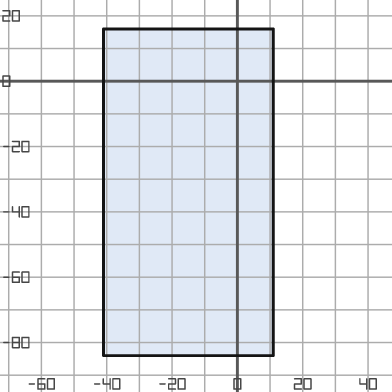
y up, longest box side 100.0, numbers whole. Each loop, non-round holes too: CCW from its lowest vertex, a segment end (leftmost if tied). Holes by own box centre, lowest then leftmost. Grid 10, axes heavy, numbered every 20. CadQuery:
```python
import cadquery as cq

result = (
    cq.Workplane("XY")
    .moveTo(-41.0, -84.0)
    .lineTo(11.0, -84.0)
    .lineTo(11.0, 16.0)
    .lineTo(-41.0, 16.0)
    .close()
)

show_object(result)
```